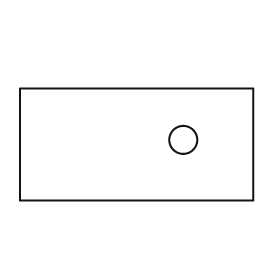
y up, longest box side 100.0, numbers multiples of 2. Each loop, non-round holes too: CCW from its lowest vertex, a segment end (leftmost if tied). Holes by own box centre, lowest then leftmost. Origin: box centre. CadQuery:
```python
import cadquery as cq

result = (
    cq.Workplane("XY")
    .moveTo(-50.0, -24.0)
    .lineTo(50.0, -24.0)
    .lineTo(50.0, 24.0)
    .lineTo(-50.0, 24.0)
    .close()
    .moveTo(20.0, 2.0)
    .circle(6.0)
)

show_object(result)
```